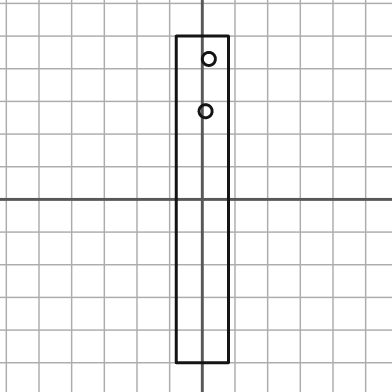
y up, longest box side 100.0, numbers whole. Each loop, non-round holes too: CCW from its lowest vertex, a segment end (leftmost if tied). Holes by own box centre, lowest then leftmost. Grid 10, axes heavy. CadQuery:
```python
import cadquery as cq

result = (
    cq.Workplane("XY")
    .moveTo(-8.0, -50.0)
    .lineTo(8.0, -50.0)
    .lineTo(8.0, 50.0)
    .lineTo(-8.0, 50.0)
    .close()
    .moveTo(1.0, 27.0)
    .circle(2.0)
    .moveTo(2.0, 43.0)
    .circle(2.0)
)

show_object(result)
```